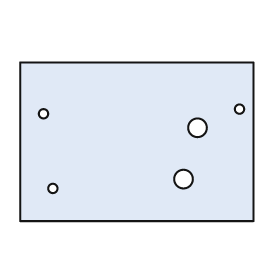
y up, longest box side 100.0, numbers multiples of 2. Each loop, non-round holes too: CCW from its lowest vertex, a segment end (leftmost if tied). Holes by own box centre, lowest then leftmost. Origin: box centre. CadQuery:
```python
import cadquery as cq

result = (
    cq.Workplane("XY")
    .moveTo(-50.0, -34.0)
    .lineTo(50.0, -34.0)
    .lineTo(50.0, 34.0)
    .lineTo(-50.0, 34.0)
    .close()
    .moveTo(-36.0, -20.0)
    .circle(2.0)
    .moveTo(20.0, -16.0)
    .circle(4.0)
    .moveTo(26.0, 6.0)
    .circle(4.0)
    .moveTo(-40.0, 12.0)
    .circle(2.0)
    .moveTo(44.0, 14.0)
    .circle(2.0)
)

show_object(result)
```